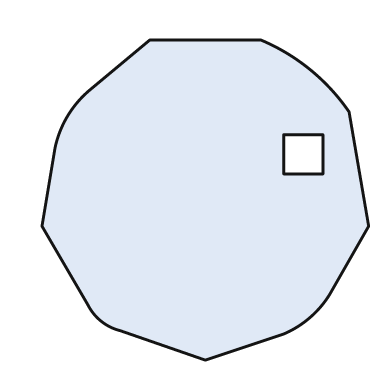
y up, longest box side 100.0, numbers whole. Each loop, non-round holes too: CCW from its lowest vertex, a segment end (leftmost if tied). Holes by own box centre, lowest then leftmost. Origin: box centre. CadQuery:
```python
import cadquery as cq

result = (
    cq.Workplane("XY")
    .moveTo(0.0, -49.0)
    .lineTo(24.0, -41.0)
    .threePointArc((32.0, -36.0), (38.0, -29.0))
    .lineTo(50.0, -8.0)
    .lineTo(44.0, 27.0)
    .threePointArc((32.0, 40.0), (17.0, 49.0))
    .lineTo(-17.0, 49.0)
    .lineTo(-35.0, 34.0)
    .threePointArc((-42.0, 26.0), (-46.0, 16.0))
    .lineTo(-50.0, -8.0)
    .lineTo(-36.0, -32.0)
    .threePointArc((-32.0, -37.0), (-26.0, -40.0))
    .close()
    .moveTo(24.0, 8.0)
    .lineTo(36.0, 8.0)
    .lineTo(36.0, 20.0)
    .lineTo(24.0, 20.0)
    .close()
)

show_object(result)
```